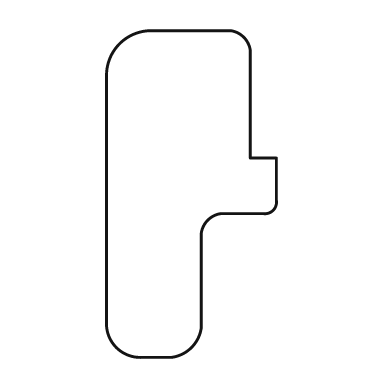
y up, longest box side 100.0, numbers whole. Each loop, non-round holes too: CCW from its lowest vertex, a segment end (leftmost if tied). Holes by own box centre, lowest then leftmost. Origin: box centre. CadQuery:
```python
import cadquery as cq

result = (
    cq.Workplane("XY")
    .moveTo(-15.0, -50.0)
    .lineTo(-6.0, -50.0)
    .threePointArc((0.0, -47.0), (3.0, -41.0))
    .lineTo(3.0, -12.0)
    .threePointArc((5.0, -8.0), (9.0, -6.0))
    .lineTo(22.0, -6.0)
    .threePointArc((25.0, -5.0), (26.0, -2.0))
    .lineTo(26.0, 11.0)
    .lineTo(18.0, 11.0)
    .lineTo(18.0, 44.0)
    .threePointArc((16.0, 48.0), (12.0, 50.0))
    .lineTo(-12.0, 50.0)
    .threePointArc((-22.0, 46.0), (-26.0, 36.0))
    .lineTo(-26.0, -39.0)
    .threePointArc((-23.0, -47.0), (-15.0, -50.0))
    .close()
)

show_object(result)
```